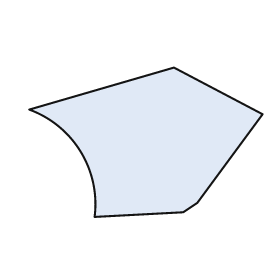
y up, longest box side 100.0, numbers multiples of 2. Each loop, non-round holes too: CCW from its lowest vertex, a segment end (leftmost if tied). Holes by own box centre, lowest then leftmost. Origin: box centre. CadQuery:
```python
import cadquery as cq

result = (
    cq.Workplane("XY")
    .moveTo(-22.0, -32.0)
    .lineTo(16.0, -30.0)
    .lineTo(22.0, -26.0)
    .lineTo(50.0, 12.0)
    .lineTo(12.0, 32.0)
    .lineTo(-50.0, 14.0)
    .threePointArc((-28.0, -4.0), (-22.0, -32.0))
    .close()
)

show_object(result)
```